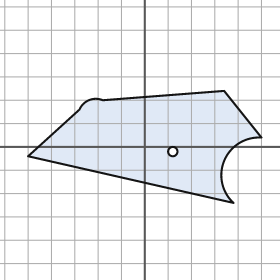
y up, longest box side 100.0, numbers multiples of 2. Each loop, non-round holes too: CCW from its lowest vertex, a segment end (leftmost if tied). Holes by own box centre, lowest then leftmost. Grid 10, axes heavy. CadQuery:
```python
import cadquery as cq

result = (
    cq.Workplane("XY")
    .moveTo(38.0, -24.0)
    .threePointArc((34.0, -6.0), (50.0, 4.0))
    .lineTo(34.0, 24.0)
    .lineTo(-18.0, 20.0)
    .threePointArc((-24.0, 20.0), (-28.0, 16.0))
    .lineTo(-50.0, -4.0)
    .close()
    .moveTo(12.0, -2.0)
    .circle(2.0)
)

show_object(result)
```